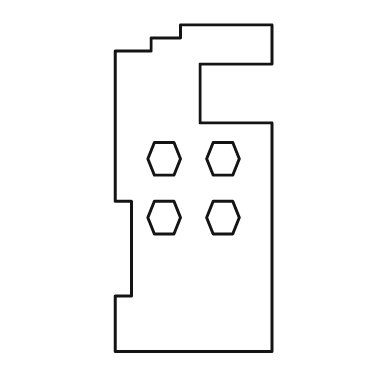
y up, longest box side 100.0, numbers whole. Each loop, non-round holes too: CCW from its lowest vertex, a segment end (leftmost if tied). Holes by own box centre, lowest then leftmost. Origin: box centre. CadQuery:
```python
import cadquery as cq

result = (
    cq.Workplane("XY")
    .moveTo(-24.0, -50.0)
    .lineTo(24.0, -50.0)
    .lineTo(24.0, 20.0)
    .lineTo(2.0, 20.0)
    .lineTo(2.0, 38.0)
    .lineTo(24.0, 38.0)
    .lineTo(24.0, 50.0)
    .lineTo(-4.0, 50.0)
    .lineTo(-4.0, 46.0)
    .lineTo(-13.0, 46.0)
    .lineTo(-13.0, 42.0)
    .lineTo(-24.0, 42.0)
    .lineTo(-24.0, -4.0)
    .lineTo(-19.0, -4.0)
    .lineTo(-19.0, -33.0)
    .lineTo(-24.0, -33.0)
    .close()
    .moveTo(-12.0, -14.0)
    .lineTo(-6.0, -14.0)
    .lineTo(-4.0, -9.0)
    .lineTo(-6.0, -4.0)
    .lineTo(-12.0, -4.0)
    .lineTo(-14.0, -9.0)
    .close()
    .moveTo(6.0, -14.0)
    .lineTo(12.0, -14.0)
    .lineTo(14.0, -9.0)
    .lineTo(12.0, -4.0)
    .lineTo(6.0, -4.0)
    .lineTo(4.0, -9.0)
    .close()
    .moveTo(-12.0, 4.0)
    .lineTo(-6.0, 4.0)
    .lineTo(-4.0, 9.0)
    .lineTo(-6.0, 14.0)
    .lineTo(-12.0, 14.0)
    .lineTo(-14.0, 9.0)
    .close()
    .moveTo(6.0, 4.0)
    .lineTo(12.0, 4.0)
    .lineTo(14.0, 9.0)
    .lineTo(12.0, 14.0)
    .lineTo(6.0, 14.0)
    .lineTo(4.0, 9.0)
    .close()
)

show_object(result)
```